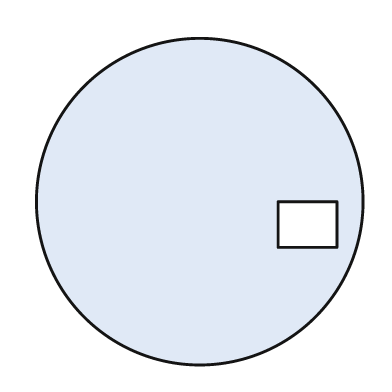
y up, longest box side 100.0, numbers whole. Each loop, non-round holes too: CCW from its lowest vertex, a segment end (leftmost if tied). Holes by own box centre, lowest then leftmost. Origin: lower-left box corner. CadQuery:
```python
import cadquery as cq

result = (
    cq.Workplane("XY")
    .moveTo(50.0, 50.0)
    .circle(50.0)
    .moveTo(74.0, 36.0)
    .lineTo(92.0, 36.0)
    .lineTo(92.0, 50.0)
    .lineTo(74.0, 50.0)
    .close()
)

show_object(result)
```